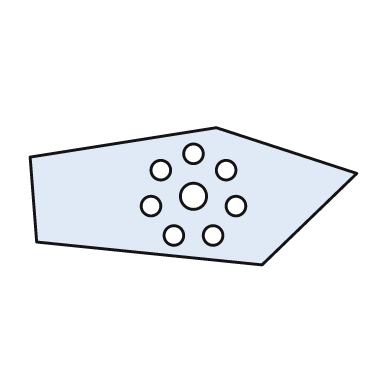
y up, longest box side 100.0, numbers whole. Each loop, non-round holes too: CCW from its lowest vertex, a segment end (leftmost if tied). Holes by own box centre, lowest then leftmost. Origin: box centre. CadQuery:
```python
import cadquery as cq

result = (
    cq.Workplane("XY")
    .moveTo(21.0, -21.0)
    .lineTo(50.0, 7.0)
    .lineTo(7.0, 21.0)
    .lineTo(-50.0, 12.0)
    .lineTo(-48.0, -14.0)
    .close()
    .moveTo(-6.0, -12.0)
    .circle(3.0)
    .moveTo(6.0, -12.0)
    .circle(3.0)
    .moveTo(-13.0, -3.0)
    .circle(3.0)
    .moveTo(13.0, -3.0)
    .circle(3.0)
    .moveTo(0.0, 0.0)
    .circle(4.0)
    .moveTo(-10.0, 8.0)
    .circle(3.0)
    .moveTo(10.0, 8.0)
    .circle(3.0)
    .moveTo(0.0, 13.0)
    .circle(3.0)
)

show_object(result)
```